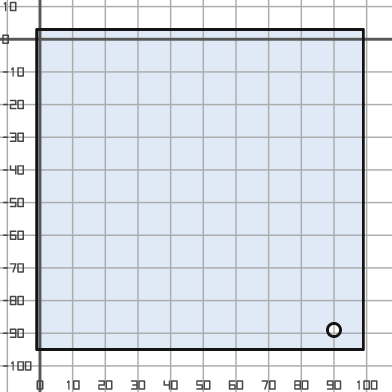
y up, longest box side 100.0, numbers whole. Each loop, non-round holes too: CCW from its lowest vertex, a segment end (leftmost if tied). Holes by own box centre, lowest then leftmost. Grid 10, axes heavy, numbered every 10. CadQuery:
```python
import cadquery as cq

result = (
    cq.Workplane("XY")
    .moveTo(-1.0, -95.0)
    .lineTo(99.0, -95.0)
    .lineTo(99.0, 3.0)
    .lineTo(-1.0, 3.0)
    .close()
    .moveTo(90.0, -89.0)
    .circle(2.0)
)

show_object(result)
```